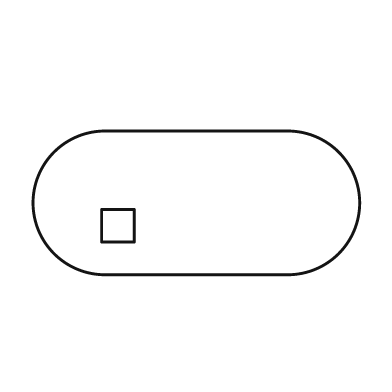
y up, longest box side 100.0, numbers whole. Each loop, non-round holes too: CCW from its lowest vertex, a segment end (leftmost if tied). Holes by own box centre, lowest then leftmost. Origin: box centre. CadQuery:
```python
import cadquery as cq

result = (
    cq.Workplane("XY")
    .moveTo(-28.0, -22.0)
    .lineTo(28.0, -22.0)
    .threePointArc((50.0, 0.0), (28.0, 22.0))
    .lineTo(-28.0, 22.0)
    .threePointArc((-50.0, 0.0), (-28.0, -22.0))
    .close()
    .moveTo(-29.0, -12.0)
    .lineTo(-19.0, -12.0)
    .lineTo(-19.0, -2.0)
    .lineTo(-29.0, -2.0)
    .close()
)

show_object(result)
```